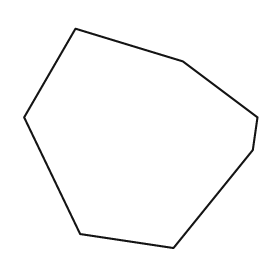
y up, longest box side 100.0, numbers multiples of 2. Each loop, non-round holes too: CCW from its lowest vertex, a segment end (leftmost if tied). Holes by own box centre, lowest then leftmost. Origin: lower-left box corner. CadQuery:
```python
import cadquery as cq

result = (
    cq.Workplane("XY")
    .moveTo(64.0, 0.0)
    .lineTo(98.0, 42.0)
    .lineTo(100.0, 56.0)
    .lineTo(68.0, 80.0)
    .lineTo(22.0, 94.0)
    .lineTo(0.0, 56.0)
    .lineTo(24.0, 6.0)
    .close()
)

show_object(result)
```